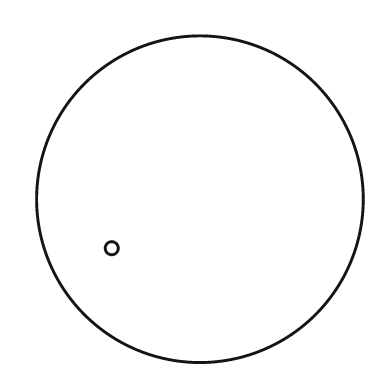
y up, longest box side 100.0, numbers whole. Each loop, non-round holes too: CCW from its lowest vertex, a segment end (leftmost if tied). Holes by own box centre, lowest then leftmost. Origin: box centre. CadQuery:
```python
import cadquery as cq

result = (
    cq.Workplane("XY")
    .moveTo(0.0, 0.0)
    .circle(50.0)
    .moveTo(-27.0, -15.0)
    .circle(2.0)
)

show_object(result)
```